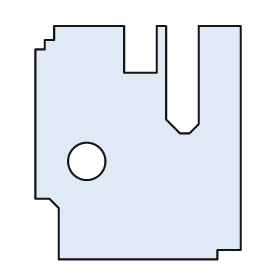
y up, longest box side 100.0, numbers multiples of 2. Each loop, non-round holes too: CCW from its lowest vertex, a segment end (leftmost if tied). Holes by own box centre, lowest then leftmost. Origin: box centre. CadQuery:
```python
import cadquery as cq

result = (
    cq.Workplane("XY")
    .moveTo(-34.0, -50.0)
    .lineTo(34.0, -50.0)
    .lineTo(34.0, -46.0)
    .lineTo(44.0, -46.0)
    .lineTo(44.0, 50.0)
    .lineTo(26.0, 50.0)
    .lineTo(26.0, 8.0)
    .lineTo(22.0, 4.0)
    .lineTo(18.0, 4.0)
    .lineTo(12.0, 10.0)
    .lineTo(12.0, 50.0)
    .lineTo(8.0, 50.0)
    .lineTo(8.0, 30.0)
    .lineTo(-6.0, 30.0)
    .lineTo(-6.0, 50.0)
    .lineTo(-36.0, 50.0)
    .lineTo(-36.0, 44.0)
    .lineTo(-40.0, 44.0)
    .lineTo(-40.0, 40.0)
    .lineTo(-44.0, 40.0)
    .lineTo(-44.0, -24.0)
    .lineTo(-38.0, -24.0)
    .lineTo(-34.0, -28.0)
    .close()
    .moveTo(-22.0, -8.0)
    .circle(8.0)
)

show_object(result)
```